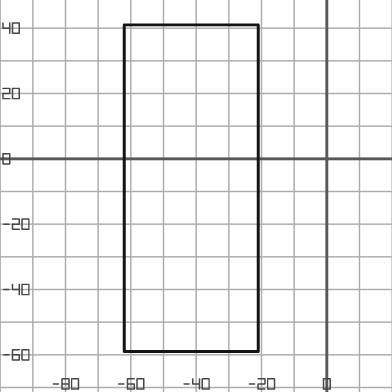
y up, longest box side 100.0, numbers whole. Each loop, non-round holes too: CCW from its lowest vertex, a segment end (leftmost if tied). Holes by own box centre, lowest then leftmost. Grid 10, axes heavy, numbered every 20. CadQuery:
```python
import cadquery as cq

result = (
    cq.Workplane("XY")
    .moveTo(-62.0, -59.0)
    .lineTo(-21.0, -59.0)
    .lineTo(-21.0, 41.0)
    .lineTo(-62.0, 41.0)
    .close()
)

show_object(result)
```